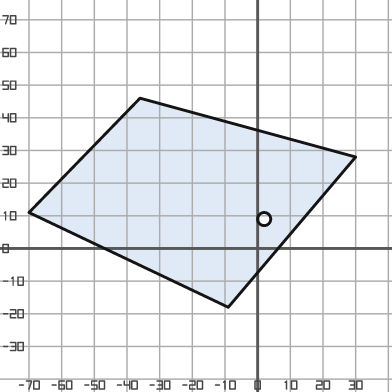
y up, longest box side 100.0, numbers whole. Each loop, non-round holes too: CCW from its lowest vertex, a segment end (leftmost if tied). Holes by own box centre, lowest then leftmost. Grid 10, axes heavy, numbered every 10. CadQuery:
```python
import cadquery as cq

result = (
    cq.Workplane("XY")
    .moveTo(-9.0, -18.0)
    .lineTo(30.0, 28.0)
    .lineTo(-36.0, 46.0)
    .lineTo(-70.0, 11.0)
    .close()
    .moveTo(2.0, 9.0)
    .circle(2.0)
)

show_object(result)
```